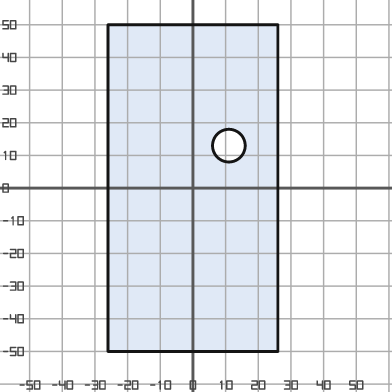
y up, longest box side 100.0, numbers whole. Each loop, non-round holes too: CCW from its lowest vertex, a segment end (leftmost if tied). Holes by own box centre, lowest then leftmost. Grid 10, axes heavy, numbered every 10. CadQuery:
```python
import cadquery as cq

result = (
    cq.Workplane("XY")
    .moveTo(-26.0, -50.0)
    .lineTo(26.0, -50.0)
    .lineTo(26.0, 50.0)
    .lineTo(-26.0, 50.0)
    .close()
    .moveTo(11.0, 13.0)
    .circle(5.0)
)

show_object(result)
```